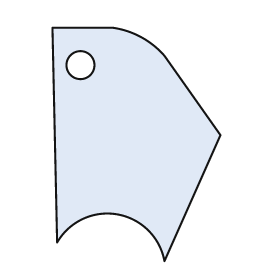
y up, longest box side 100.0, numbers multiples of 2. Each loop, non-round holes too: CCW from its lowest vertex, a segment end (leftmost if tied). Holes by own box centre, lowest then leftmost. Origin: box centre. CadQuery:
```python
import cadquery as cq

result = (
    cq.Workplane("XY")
    .moveTo(12.0, -50.0)
    .lineTo(36.0, 4.0)
    .lineTo(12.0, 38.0)
    .threePointArc((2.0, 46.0), (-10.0, 50.0))
    .lineTo(-36.0, 50.0)
    .lineTo(-34.0, -42.0)
    .threePointArc((-8.0, -30.0), (12.0, -50.0))
    .close()
    .moveTo(-24.0, 34.0)
    .circle(6.0)
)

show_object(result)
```